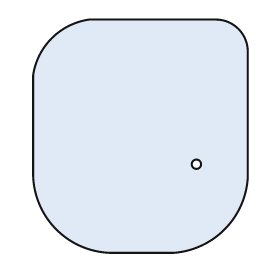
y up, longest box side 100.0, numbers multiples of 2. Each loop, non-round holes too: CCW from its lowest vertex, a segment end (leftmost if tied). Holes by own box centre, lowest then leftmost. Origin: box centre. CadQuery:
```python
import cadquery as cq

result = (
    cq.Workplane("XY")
    .moveTo(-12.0, -50.0)
    .lineTo(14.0, -50.0)
    .threePointArc((36.0, -40.0), (46.0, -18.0))
    .lineTo(46.0, 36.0)
    .threePointArc((42.0, 46.0), (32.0, 50.0))
    .lineTo(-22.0, 50.0)
    .threePointArc((-38.0, 42.0), (-46.0, 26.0))
    .lineTo(-46.0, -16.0)
    .threePointArc((-36.0, -40.0), (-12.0, -50.0))
    .close()
    .moveTo(24.0, -12.0)
    .circle(2.0)
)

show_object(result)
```